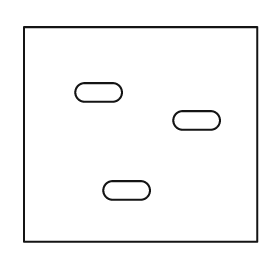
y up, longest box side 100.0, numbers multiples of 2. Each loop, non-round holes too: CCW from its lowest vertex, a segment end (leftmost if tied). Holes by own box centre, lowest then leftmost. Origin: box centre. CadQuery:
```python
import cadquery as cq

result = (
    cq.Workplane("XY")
    .moveTo(-50.0, -46.0)
    .lineTo(50.0, -46.0)
    .lineTo(50.0, 46.0)
    .lineTo(-50.0, 46.0)
    .close()
    .moveTo(-12.0, -28.0)
    .lineTo(0.0, -28.0)
    .threePointArc((4.0, -24.0), (0.0, -20.0))
    .lineTo(-12.0, -20.0)
    .threePointArc((-16.0, -24.0), (-12.0, -28.0))
    .close()
    .moveTo(18.0, 2.0)
    .lineTo(30.0, 2.0)
    .threePointArc((34.0, 6.0), (30.0, 10.0))
    .lineTo(18.0, 10.0)
    .threePointArc((14.0, 6.0), (18.0, 2.0))
    .close()
    .moveTo(-24.0, 14.0)
    .lineTo(-12.0, 14.0)
    .threePointArc((-8.0, 18.0), (-12.0, 22.0))
    .lineTo(-24.0, 22.0)
    .threePointArc((-28.0, 18.0), (-24.0, 14.0))
    .close()
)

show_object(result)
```